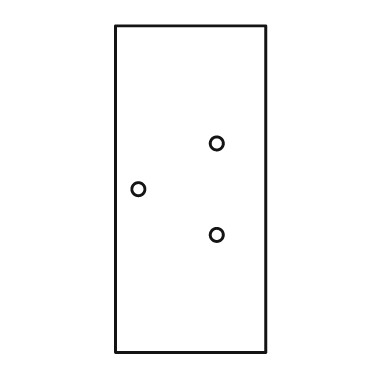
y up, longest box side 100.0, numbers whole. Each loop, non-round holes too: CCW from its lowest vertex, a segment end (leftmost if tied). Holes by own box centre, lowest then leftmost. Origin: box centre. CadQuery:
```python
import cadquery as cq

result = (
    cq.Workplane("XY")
    .moveTo(-23.0, -50.0)
    .lineTo(23.0, -50.0)
    .lineTo(23.0, 50.0)
    .lineTo(-23.0, 50.0)
    .close()
    .moveTo(8.0, -14.0)
    .circle(2.0)
    .moveTo(-16.0, 0.0)
    .circle(2.0)
    .moveTo(8.0, 14.0)
    .circle(2.0)
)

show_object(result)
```